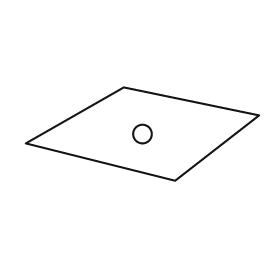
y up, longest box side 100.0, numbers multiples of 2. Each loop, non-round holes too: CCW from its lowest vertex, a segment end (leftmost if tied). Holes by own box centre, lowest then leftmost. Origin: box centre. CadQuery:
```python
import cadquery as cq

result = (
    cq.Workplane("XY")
    .moveTo(14.0, -20.0)
    .lineTo(50.0, 8.0)
    .lineTo(-8.0, 20.0)
    .lineTo(-50.0, -4.0)
    .close()
    .moveTo(0.0, 0.0)
    .circle(4.0)
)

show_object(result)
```